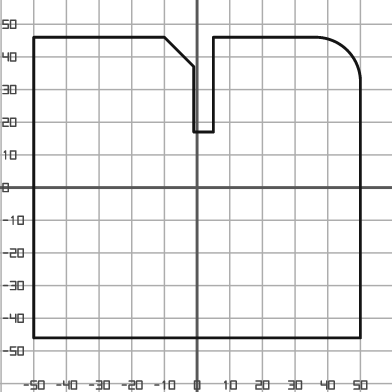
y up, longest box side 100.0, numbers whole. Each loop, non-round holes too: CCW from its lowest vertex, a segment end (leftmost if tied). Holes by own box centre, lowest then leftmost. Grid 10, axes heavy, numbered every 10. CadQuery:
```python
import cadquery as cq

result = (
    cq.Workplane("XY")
    .moveTo(-50.0, -46.0)
    .lineTo(50.0, -46.0)
    .lineTo(50.0, 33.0)
    .threePointArc((46.0, 42.0), (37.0, 46.0))
    .lineTo(5.0, 46.0)
    .lineTo(5.0, 17.0)
    .lineTo(-1.0, 17.0)
    .lineTo(-1.0, 37.0)
    .lineTo(-10.0, 46.0)
    .lineTo(-50.0, 46.0)
    .close()
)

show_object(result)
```